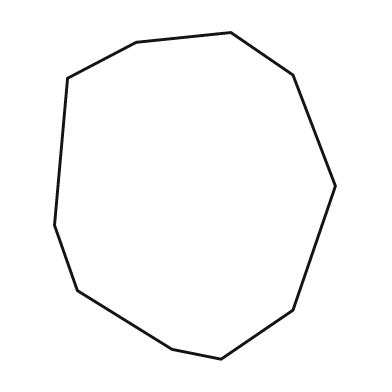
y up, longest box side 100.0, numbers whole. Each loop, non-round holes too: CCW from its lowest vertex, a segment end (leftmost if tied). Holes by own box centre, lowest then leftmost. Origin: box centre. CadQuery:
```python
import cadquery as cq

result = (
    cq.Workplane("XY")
    .moveTo(8.0, -50.0)
    .lineTo(30.0, -35.0)
    .lineTo(43.0, 3.0)
    .lineTo(30.0, 37.0)
    .lineTo(11.0, 50.0)
    .lineTo(-18.0, 47.0)
    .lineTo(-39.0, 36.0)
    .lineTo(-43.0, -9.0)
    .lineTo(-36.0, -29.0)
    .lineTo(-7.0, -47.0)
    .close()
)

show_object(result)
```